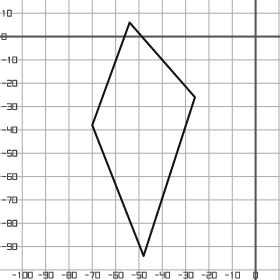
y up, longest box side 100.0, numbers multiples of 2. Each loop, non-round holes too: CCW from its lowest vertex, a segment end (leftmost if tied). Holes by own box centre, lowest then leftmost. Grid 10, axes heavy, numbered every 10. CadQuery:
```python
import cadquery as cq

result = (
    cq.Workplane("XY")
    .moveTo(-48.0, -94.0)
    .lineTo(-26.0, -26.0)
    .lineTo(-54.0, 6.0)
    .lineTo(-70.0, -38.0)
    .close()
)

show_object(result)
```